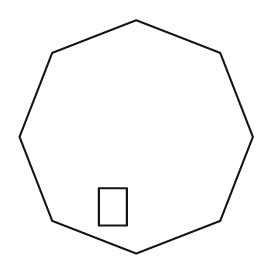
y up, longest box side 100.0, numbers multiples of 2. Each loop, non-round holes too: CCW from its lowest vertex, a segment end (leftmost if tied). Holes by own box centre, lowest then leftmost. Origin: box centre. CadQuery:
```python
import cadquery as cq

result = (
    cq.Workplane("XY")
    .moveTo(0.0, -50.0)
    .lineTo(36.0, -36.0)
    .lineTo(50.0, 0.0)
    .lineTo(36.0, 36.0)
    .lineTo(0.0, 50.0)
    .lineTo(-36.0, 36.0)
    .lineTo(-50.0, 0.0)
    .lineTo(-36.0, -36.0)
    .close()
    .moveTo(-16.0, -38.0)
    .lineTo(-4.0, -38.0)
    .lineTo(-4.0, -22.0)
    .lineTo(-16.0, -22.0)
    .close()
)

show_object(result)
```